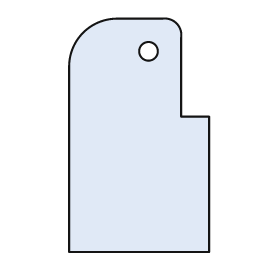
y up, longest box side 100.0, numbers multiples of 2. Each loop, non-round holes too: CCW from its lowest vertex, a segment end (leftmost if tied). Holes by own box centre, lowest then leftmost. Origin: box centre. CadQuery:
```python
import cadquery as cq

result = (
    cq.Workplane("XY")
    .moveTo(-30.0, -50.0)
    .lineTo(30.0, -50.0)
    .lineTo(30.0, 8.0)
    .lineTo(18.0, 8.0)
    .lineTo(18.0, 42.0)
    .threePointArc((16.0, 48.0), (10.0, 50.0))
    .lineTo(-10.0, 50.0)
    .threePointArc((-24.0, 44.0), (-30.0, 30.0))
    .close()
    .moveTo(4.0, 36.0)
    .circle(4.0)
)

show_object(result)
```